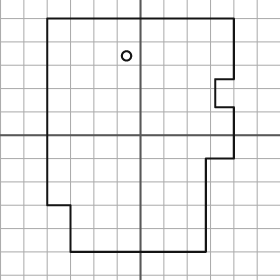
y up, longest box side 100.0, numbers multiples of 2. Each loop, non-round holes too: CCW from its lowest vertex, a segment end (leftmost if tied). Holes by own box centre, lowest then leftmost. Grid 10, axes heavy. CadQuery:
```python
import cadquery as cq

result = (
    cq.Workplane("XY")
    .moveTo(-30.0, -50.0)
    .lineTo(28.0, -50.0)
    .lineTo(28.0, -10.0)
    .lineTo(40.0, -10.0)
    .lineTo(40.0, 12.0)
    .lineTo(32.0, 12.0)
    .lineTo(32.0, 24.0)
    .lineTo(40.0, 24.0)
    .lineTo(40.0, 50.0)
    .lineTo(-40.0, 50.0)
    .lineTo(-40.0, -30.0)
    .lineTo(-30.0, -30.0)
    .close()
    .moveTo(-6.0, 34.0)
    .circle(2.0)
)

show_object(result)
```